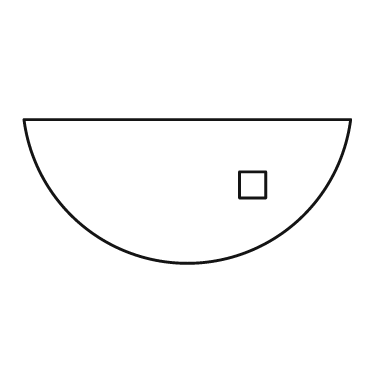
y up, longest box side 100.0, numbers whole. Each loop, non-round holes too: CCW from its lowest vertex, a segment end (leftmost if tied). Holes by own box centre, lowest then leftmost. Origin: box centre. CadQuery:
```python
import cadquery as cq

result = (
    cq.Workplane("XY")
    .moveTo(-50.0, 22.0)
    .threePointArc((0.0, -22.0), (50.0, 22.0))
    .close()
    .moveTo(16.0, -2.0)
    .lineTo(24.0, -2.0)
    .lineTo(24.0, 6.0)
    .lineTo(16.0, 6.0)
    .close()
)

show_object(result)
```